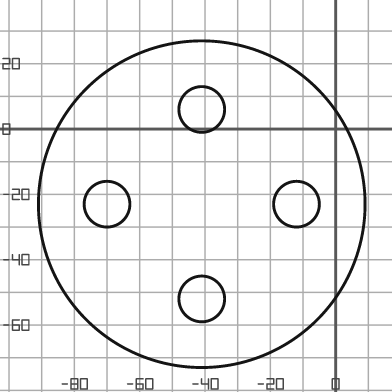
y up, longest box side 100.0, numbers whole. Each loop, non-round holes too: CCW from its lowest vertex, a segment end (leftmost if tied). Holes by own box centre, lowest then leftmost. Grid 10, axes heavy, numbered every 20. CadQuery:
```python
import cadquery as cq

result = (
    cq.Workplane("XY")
    .moveTo(-41.0, -23.0)
    .circle(50.0)
    .moveTo(-41.0, -52.0)
    .circle(7.0)
    .moveTo(-70.0, -23.0)
    .circle(7.0)
    .moveTo(-12.0, -23.0)
    .circle(7.0)
    .moveTo(-41.0, 6.0)
    .circle(7.0)
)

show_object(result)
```